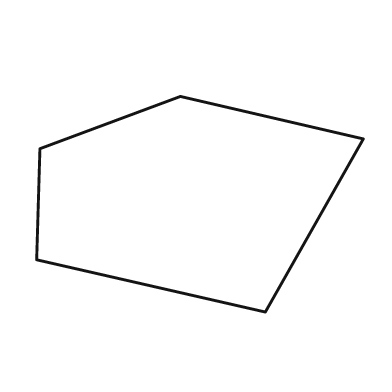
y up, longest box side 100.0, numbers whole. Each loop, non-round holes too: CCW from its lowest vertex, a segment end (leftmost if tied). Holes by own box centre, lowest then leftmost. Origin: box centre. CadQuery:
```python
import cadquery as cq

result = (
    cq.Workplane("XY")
    .moveTo(20.0, -33.0)
    .lineTo(50.0, 20.0)
    .lineTo(-6.0, 33.0)
    .lineTo(-49.0, 17.0)
    .lineTo(-50.0, -17.0)
    .close()
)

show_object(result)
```